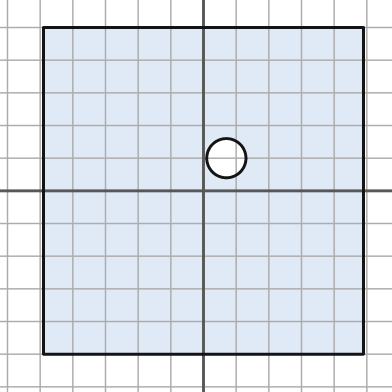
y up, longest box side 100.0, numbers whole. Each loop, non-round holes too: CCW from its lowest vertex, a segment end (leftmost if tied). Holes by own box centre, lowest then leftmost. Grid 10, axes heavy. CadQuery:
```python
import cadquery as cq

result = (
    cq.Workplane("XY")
    .moveTo(-49.0, -50.0)
    .lineTo(49.0, -50.0)
    .lineTo(49.0, 50.0)
    .lineTo(-49.0, 50.0)
    .close()
    .moveTo(7.0, 10.0)
    .circle(6.0)
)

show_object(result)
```